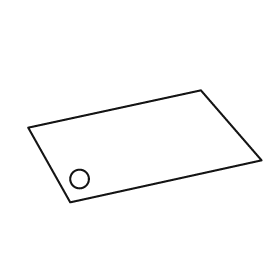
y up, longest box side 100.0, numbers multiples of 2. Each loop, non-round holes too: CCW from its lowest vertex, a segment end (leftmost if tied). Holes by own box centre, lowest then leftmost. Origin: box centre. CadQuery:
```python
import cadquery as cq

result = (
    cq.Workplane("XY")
    .moveTo(-32.0, -24.0)
    .lineTo(50.0, -6.0)
    .lineTo(24.0, 24.0)
    .lineTo(-50.0, 8.0)
    .close()
    .moveTo(-28.0, -14.0)
    .circle(4.0)
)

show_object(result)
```